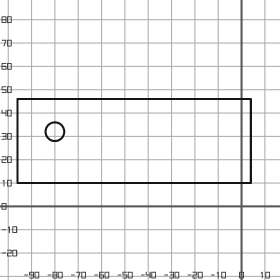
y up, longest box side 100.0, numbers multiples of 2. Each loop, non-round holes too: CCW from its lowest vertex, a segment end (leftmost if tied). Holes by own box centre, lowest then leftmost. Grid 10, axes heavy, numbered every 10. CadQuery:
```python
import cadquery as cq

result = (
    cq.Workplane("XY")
    .moveTo(-96.0, 10.0)
    .lineTo(4.0, 10.0)
    .lineTo(4.0, 46.0)
    .lineTo(-96.0, 46.0)
    .close()
    .moveTo(-80.0, 32.0)
    .circle(4.0)
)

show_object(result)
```